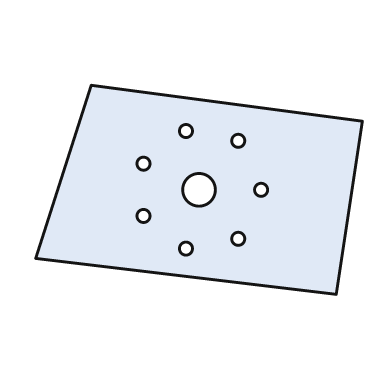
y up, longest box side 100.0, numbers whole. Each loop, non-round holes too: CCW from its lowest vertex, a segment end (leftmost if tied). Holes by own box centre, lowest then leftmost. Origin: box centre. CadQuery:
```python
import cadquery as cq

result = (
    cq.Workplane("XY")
    .moveTo(42.0, -32.0)
    .lineTo(50.0, 21.0)
    .lineTo(-33.0, 32.0)
    .lineTo(-50.0, -21.0)
    .close()
    .moveTo(-4.0, -18.0)
    .circle(2.0)
    .moveTo(12.0, -15.0)
    .circle(2.0)
    .moveTo(-17.0, -8.0)
    .circle(2.0)
    .moveTo(0.0, 0.0)
    .circle(5.0)
    .moveTo(19.0, 0.0)
    .circle(2.0)
    .moveTo(-17.0, 8.0)
    .circle(2.0)
    .moveTo(12.0, 15.0)
    .circle(2.0)
    .moveTo(-4.0, 18.0)
    .circle(2.0)
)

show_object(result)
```